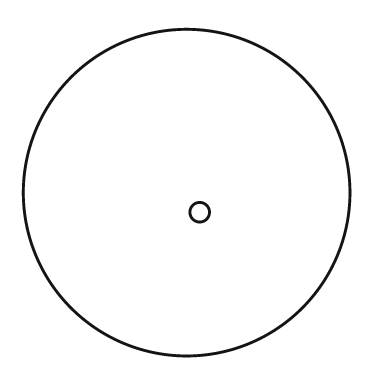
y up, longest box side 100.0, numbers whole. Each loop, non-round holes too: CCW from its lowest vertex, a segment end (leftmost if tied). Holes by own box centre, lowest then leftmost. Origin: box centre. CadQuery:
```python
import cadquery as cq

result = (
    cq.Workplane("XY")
    .moveTo(0.0, 0.0)
    .circle(50.0)
    .moveTo(4.0, -6.0)
    .circle(3.0)
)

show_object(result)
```